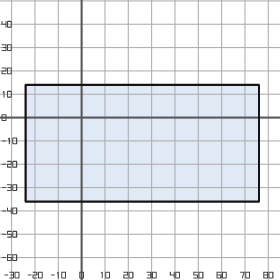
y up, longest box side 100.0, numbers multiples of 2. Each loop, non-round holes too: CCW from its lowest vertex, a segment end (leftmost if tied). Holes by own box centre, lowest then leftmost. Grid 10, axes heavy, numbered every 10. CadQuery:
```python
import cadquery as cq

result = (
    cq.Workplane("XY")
    .moveTo(-24.0, -36.0)
    .lineTo(76.0, -36.0)
    .lineTo(76.0, 14.0)
    .lineTo(-24.0, 14.0)
    .close()
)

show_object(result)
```